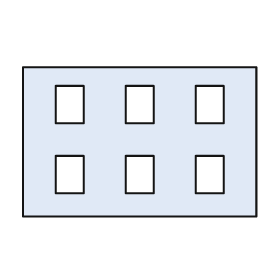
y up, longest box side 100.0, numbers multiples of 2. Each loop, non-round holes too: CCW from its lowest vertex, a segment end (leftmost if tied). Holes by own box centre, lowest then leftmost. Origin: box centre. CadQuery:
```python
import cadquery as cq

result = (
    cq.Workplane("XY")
    .moveTo(-50.0, -32.0)
    .lineTo(50.0, -32.0)
    .lineTo(50.0, 32.0)
    .lineTo(-50.0, 32.0)
    .close()
    .moveTo(-36.0, -22.0)
    .lineTo(-24.0, -22.0)
    .lineTo(-24.0, -6.0)
    .lineTo(-36.0, -6.0)
    .close()
    .moveTo(-6.0, -22.0)
    .lineTo(6.0, -22.0)
    .lineTo(6.0, -6.0)
    .lineTo(-6.0, -6.0)
    .close()
    .moveTo(24.0, -22.0)
    .lineTo(36.0, -22.0)
    .lineTo(36.0, -6.0)
    .lineTo(24.0, -6.0)
    .close()
    .moveTo(-36.0, 8.0)
    .lineTo(-24.0, 8.0)
    .lineTo(-24.0, 24.0)
    .lineTo(-36.0, 24.0)
    .close()
    .moveTo(-6.0, 8.0)
    .lineTo(6.0, 8.0)
    .lineTo(6.0, 24.0)
    .lineTo(-6.0, 24.0)
    .close()
    .moveTo(24.0, 8.0)
    .lineTo(36.0, 8.0)
    .lineTo(36.0, 24.0)
    .lineTo(24.0, 24.0)
    .close()
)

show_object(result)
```